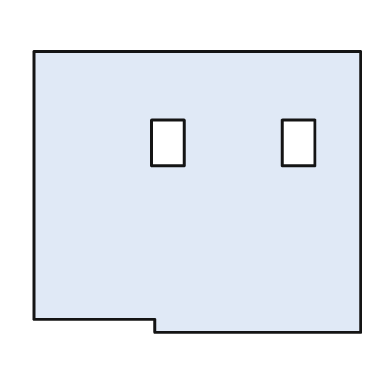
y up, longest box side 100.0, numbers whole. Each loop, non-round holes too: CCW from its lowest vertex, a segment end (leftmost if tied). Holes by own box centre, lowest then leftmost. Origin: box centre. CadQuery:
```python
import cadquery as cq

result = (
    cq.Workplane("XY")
    .moveTo(-13.0, -43.0)
    .lineTo(50.0, -43.0)
    .lineTo(50.0, 43.0)
    .lineTo(-50.0, 43.0)
    .lineTo(-50.0, -39.0)
    .lineTo(-13.0, -39.0)
    .close()
    .moveTo(-14.0, 8.0)
    .lineTo(-4.0, 8.0)
    .lineTo(-4.0, 22.0)
    .lineTo(-14.0, 22.0)
    .close()
    .moveTo(26.0, 8.0)
    .lineTo(36.0, 8.0)
    .lineTo(36.0, 22.0)
    .lineTo(26.0, 22.0)
    .close()
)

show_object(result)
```